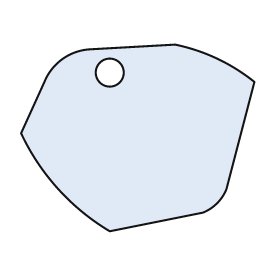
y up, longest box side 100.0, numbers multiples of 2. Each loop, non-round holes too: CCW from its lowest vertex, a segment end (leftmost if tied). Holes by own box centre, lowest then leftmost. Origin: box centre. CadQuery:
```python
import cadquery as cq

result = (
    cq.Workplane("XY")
    .moveTo(-12.0, -40.0)
    .lineTo(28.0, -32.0)
    .threePointArc((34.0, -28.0), (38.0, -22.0))
    .lineTo(50.0, 24.0)
    .threePointArc((34.0, 34.0), (16.0, 40.0))
    .lineTo(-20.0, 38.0)
    .threePointArc((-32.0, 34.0), (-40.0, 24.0))
    .lineTo(-50.0, 2.0)
    .threePointArc((-34.0, -22.0), (-12.0, -40.0))
    .close()
    .moveTo(-12.0, 28.0)
    .circle(6.0)
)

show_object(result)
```